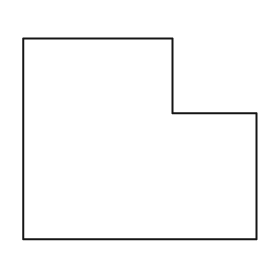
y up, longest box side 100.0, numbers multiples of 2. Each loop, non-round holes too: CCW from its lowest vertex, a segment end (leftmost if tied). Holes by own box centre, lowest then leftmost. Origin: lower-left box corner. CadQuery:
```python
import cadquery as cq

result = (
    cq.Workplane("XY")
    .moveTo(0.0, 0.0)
    .lineTo(100.0, 0.0)
    .lineTo(100.0, 54.0)
    .lineTo(64.0, 54.0)
    .lineTo(64.0, 86.0)
    .lineTo(0.0, 86.0)
    .close()
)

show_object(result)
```